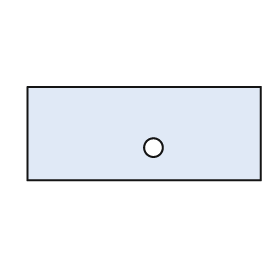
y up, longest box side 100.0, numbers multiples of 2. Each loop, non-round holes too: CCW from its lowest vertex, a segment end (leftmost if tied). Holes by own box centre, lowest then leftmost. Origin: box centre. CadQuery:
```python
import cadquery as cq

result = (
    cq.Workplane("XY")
    .moveTo(-50.0, -20.0)
    .lineTo(50.0, -20.0)
    .lineTo(50.0, 20.0)
    .lineTo(-50.0, 20.0)
    .close()
    .moveTo(4.0, -6.0)
    .circle(4.0)
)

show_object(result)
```